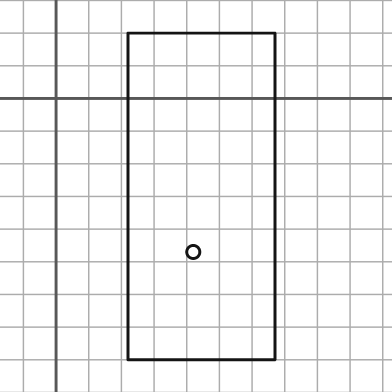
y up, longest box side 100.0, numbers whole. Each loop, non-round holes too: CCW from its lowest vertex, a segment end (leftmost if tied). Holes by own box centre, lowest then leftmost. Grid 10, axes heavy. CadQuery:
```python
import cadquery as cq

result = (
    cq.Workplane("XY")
    .moveTo(22.0, -80.0)
    .lineTo(67.0, -80.0)
    .lineTo(67.0, 20.0)
    .lineTo(22.0, 20.0)
    .close()
    .moveTo(42.0, -47.0)
    .circle(2.0)
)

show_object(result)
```